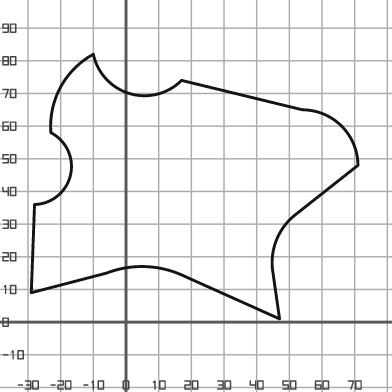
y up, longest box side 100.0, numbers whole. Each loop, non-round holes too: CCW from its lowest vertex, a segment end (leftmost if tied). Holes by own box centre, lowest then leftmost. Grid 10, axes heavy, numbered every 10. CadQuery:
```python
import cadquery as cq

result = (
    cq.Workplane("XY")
    .moveTo(47.0, 1.0)
    .lineTo(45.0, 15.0)
    .threePointArc((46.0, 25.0), (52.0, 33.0))
    .lineTo(71.0, 48.0)
    .threePointArc((66.0, 60.0), (54.0, 65.0))
    .lineTo(17.0, 74.0)
    .threePointArc((1.0, 70.0), (-10.0, 82.0))
    .threePointArc((-20.0, 72.0), (-23.0, 58.0))
    .threePointArc((-17.0, 45.0), (-28.0, 36.0))
    .lineTo(-29.0, 9.0)
    .lineTo(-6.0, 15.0)
    .threePointArc((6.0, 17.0), (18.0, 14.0))
    .close()
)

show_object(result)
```